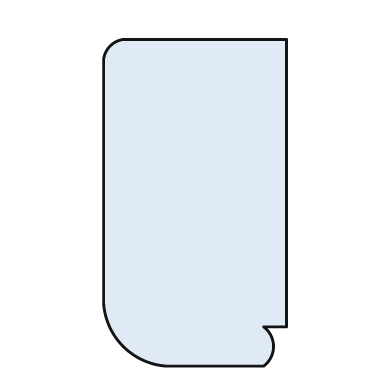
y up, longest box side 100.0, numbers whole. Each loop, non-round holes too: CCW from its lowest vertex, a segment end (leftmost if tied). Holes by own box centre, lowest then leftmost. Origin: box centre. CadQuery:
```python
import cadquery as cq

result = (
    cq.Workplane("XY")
    .moveTo(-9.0, -50.0)
    .lineTo(21.0, -50.0)
    .threePointArc((24.0, -44.0), (21.0, -38.0))
    .lineTo(28.0, -38.0)
    .lineTo(28.0, 50.0)
    .lineTo(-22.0, 50.0)
    .threePointArc((-26.0, 48.0), (-28.0, 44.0))
    .lineTo(-28.0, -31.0)
    .threePointArc((-22.0, -44.0), (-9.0, -50.0))
    .close()
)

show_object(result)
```